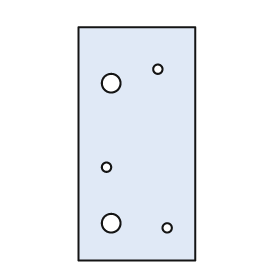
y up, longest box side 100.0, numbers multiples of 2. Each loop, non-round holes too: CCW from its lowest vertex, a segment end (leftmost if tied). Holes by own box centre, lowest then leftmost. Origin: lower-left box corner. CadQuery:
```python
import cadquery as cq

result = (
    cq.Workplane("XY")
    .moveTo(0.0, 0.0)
    .lineTo(50.0, 0.0)
    .lineTo(50.0, 100.0)
    .lineTo(0.0, 100.0)
    .close()
    .moveTo(38.0, 14.0)
    .circle(2.0)
    .moveTo(14.0, 16.0)
    .circle(4.0)
    .moveTo(12.0, 40.0)
    .circle(2.0)
    .moveTo(14.0, 76.0)
    .circle(4.0)
    .moveTo(34.0, 82.0)
    .circle(2.0)
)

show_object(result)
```